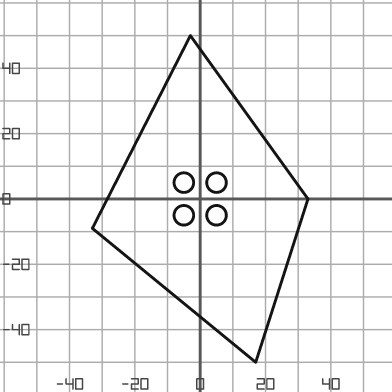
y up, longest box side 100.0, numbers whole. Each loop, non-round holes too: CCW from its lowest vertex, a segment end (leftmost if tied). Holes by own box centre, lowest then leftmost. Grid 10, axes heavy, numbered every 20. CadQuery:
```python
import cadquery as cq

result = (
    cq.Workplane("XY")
    .moveTo(17.0, -50.0)
    .lineTo(33.0, 0.0)
    .lineTo(-3.0, 50.0)
    .lineTo(-33.0, -9.0)
    .close()
    .moveTo(-5.0, -5.0)
    .circle(3.0)
    .moveTo(5.0, -5.0)
    .circle(3.0)
    .moveTo(-5.0, 5.0)
    .circle(3.0)
    .moveTo(5.0, 5.0)
    .circle(3.0)
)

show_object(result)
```